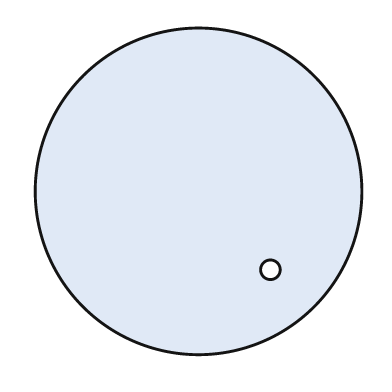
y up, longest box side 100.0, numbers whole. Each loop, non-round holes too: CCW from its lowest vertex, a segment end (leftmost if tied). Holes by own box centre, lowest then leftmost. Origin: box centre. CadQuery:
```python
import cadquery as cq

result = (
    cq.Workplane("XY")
    .moveTo(0.0, 0.0)
    .circle(50.0)
    .moveTo(22.0, -24.0)
    .circle(3.0)
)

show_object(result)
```